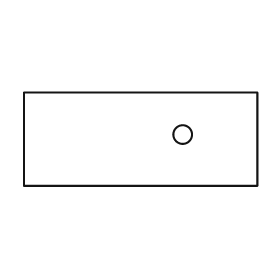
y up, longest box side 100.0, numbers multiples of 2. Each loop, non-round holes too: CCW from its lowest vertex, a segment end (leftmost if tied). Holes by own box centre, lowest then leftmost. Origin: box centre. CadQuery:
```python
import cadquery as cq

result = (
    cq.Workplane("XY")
    .moveTo(-50.0, -20.0)
    .lineTo(50.0, -20.0)
    .lineTo(50.0, 20.0)
    .lineTo(-50.0, 20.0)
    .close()
    .moveTo(18.0, 2.0)
    .circle(4.0)
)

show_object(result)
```